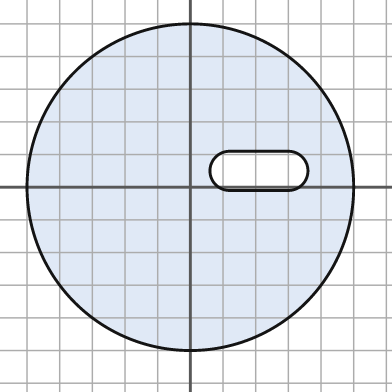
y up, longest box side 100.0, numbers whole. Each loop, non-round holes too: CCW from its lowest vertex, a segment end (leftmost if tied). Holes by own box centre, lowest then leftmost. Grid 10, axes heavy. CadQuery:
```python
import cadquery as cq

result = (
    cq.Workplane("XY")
    .moveTo(0.0, 0.0)
    .circle(50.0)
    .moveTo(12.0, -1.0)
    .lineTo(30.0, -1.0)
    .threePointArc((36.0, 5.0), (30.0, 11.0))
    .lineTo(12.0, 11.0)
    .threePointArc((6.0, 5.0), (12.0, -1.0))
    .close()
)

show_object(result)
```